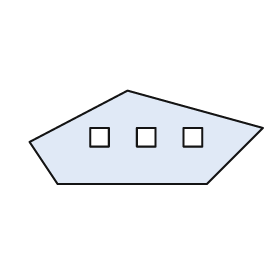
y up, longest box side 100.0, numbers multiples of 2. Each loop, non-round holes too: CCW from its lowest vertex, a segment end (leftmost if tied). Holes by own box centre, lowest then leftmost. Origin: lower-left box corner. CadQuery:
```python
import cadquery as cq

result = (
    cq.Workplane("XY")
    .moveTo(12.0, 0.0)
    .lineTo(76.0, 0.0)
    .lineTo(100.0, 24.0)
    .lineTo(42.0, 40.0)
    .lineTo(0.0, 18.0)
    .close()
    .moveTo(26.0, 16.0)
    .lineTo(34.0, 16.0)
    .lineTo(34.0, 24.0)
    .lineTo(26.0, 24.0)
    .close()
    .moveTo(46.0, 16.0)
    .lineTo(54.0, 16.0)
    .lineTo(54.0, 24.0)
    .lineTo(46.0, 24.0)
    .close()
    .moveTo(66.0, 16.0)
    .lineTo(74.0, 16.0)
    .lineTo(74.0, 24.0)
    .lineTo(66.0, 24.0)
    .close()
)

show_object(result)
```